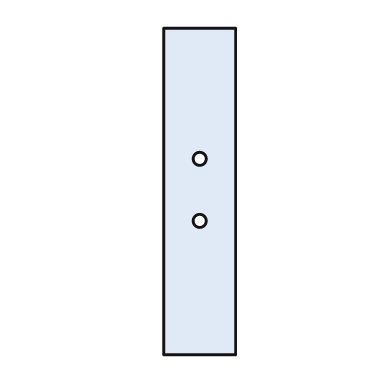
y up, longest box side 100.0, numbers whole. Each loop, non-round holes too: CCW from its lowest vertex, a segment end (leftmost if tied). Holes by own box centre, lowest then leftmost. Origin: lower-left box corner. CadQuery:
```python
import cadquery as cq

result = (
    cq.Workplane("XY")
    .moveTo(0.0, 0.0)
    .lineTo(22.0, 0.0)
    .lineTo(22.0, 100.0)
    .lineTo(0.0, 100.0)
    .close()
    .moveTo(11.0, 41.0)
    .circle(2.0)
    .moveTo(11.0, 60.0)
    .circle(2.0)
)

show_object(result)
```